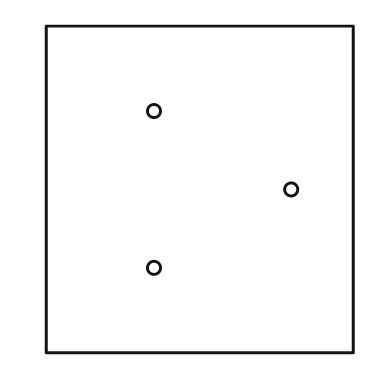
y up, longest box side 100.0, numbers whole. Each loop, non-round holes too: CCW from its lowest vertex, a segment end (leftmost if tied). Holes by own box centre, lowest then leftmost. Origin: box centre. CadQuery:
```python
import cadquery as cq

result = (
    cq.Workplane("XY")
    .moveTo(-47.0, -50.0)
    .lineTo(47.0, -50.0)
    .lineTo(47.0, 50.0)
    .lineTo(-47.0, 50.0)
    .close()
    .moveTo(-14.0, -24.0)
    .circle(2.0)
    .moveTo(28.0, 0.0)
    .circle(2.0)
    .moveTo(-14.0, 24.0)
    .circle(2.0)
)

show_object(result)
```